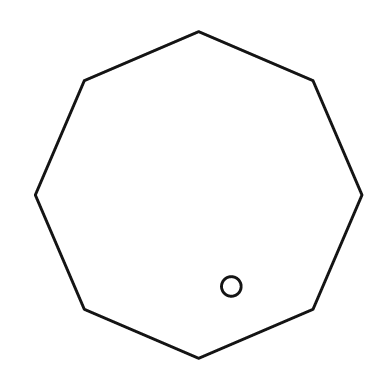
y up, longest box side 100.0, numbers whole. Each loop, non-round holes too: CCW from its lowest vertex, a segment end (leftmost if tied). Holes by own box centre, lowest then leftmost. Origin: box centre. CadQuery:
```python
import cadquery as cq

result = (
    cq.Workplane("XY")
    .moveTo(0.0, -50.0)
    .lineTo(35.0, -35.0)
    .lineTo(50.0, 0.0)
    .lineTo(35.0, 35.0)
    .lineTo(0.0, 50.0)
    .lineTo(-35.0, 35.0)
    .lineTo(-50.0, 0.0)
    .lineTo(-35.0, -35.0)
    .close()
    .moveTo(10.0, -28.0)
    .circle(3.0)
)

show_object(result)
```